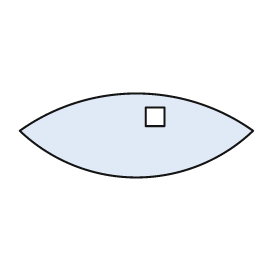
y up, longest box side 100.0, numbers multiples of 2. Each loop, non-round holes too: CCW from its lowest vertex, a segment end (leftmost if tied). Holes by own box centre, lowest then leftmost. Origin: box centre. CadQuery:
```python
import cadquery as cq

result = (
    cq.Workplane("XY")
    .moveTo(-50.0, 2.0)
    .threePointArc((0.0, -18.0), (50.0, 2.0))
    .threePointArc((0.0, 18.0), (-50.0, 2.0))
    .close()
    .moveTo(4.0, 4.0)
    .lineTo(12.0, 4.0)
    .lineTo(12.0, 12.0)
    .lineTo(4.0, 12.0)
    .close()
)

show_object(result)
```